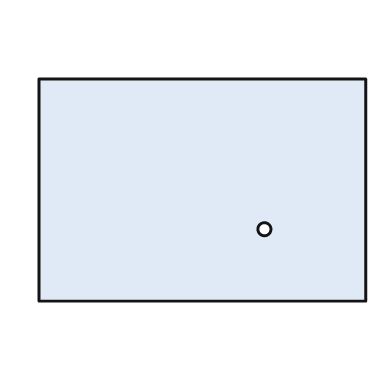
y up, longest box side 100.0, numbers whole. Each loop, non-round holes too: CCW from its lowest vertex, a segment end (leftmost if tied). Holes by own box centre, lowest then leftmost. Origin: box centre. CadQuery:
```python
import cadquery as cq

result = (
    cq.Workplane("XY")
    .moveTo(-50.0, -34.0)
    .lineTo(50.0, -34.0)
    .lineTo(50.0, 34.0)
    .lineTo(-50.0, 34.0)
    .close()
    .moveTo(19.0, -12.0)
    .circle(2.0)
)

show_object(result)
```